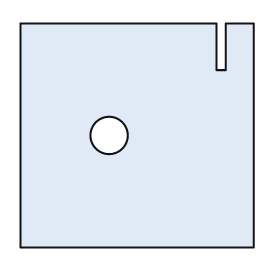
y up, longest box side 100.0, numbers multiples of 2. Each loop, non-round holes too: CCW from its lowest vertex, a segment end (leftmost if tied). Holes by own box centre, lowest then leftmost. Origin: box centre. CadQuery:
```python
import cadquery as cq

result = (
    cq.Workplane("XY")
    .moveTo(-50.0, -48.0)
    .lineTo(50.0, -48.0)
    .lineTo(50.0, 48.0)
    .lineTo(38.0, 48.0)
    .lineTo(38.0, 28.0)
    .lineTo(34.0, 28.0)
    .lineTo(34.0, 48.0)
    .lineTo(-50.0, 48.0)
    .close()
    .moveTo(-12.0, 0.0)
    .circle(8.0)
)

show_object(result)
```